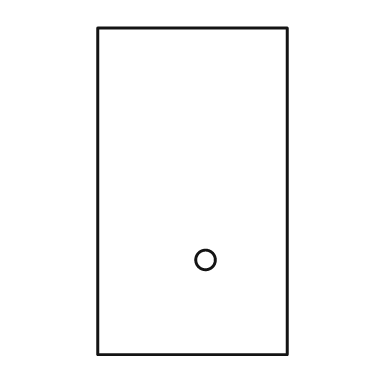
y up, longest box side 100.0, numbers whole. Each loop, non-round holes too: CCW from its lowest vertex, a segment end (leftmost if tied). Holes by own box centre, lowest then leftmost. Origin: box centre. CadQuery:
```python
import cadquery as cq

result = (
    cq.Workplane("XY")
    .moveTo(-29.0, -50.0)
    .lineTo(29.0, -50.0)
    .lineTo(29.0, 50.0)
    .lineTo(-29.0, 50.0)
    .close()
    .moveTo(4.0, -21.0)
    .circle(3.0)
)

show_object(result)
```